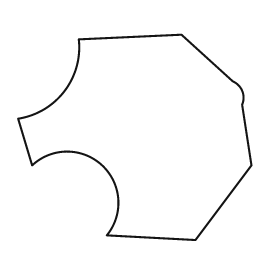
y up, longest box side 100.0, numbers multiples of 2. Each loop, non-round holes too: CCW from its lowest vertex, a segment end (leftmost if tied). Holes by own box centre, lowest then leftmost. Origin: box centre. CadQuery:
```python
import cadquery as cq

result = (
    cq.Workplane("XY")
    .moveTo(26.0, -44.0)
    .lineTo(50.0, -12.0)
    .lineTo(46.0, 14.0)
    .threePointArc((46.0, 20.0), (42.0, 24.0))
    .lineTo(20.0, 44.0)
    .lineTo(-24.0, 42.0)
    .threePointArc((-30.0, 20.0), (-50.0, 8.0))
    .lineTo(-44.0, -12.0)
    .threePointArc((-14.0, -12.0), (-12.0, -42.0))
    .close()
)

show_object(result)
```